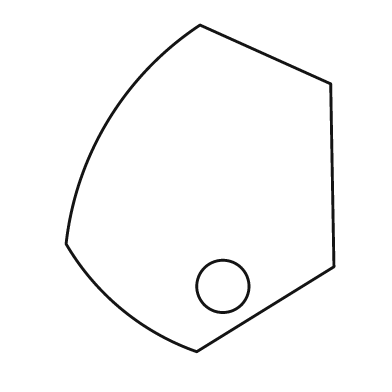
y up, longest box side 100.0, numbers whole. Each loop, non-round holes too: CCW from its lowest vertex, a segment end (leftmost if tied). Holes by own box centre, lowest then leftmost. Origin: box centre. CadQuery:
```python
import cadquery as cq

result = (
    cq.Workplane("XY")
    .moveTo(-1.0, -50.0)
    .lineTo(41.0, -24.0)
    .lineTo(40.0, 32.0)
    .lineTo(0.0, 50.0)
    .threePointArc((-28.0, 21.0), (-41.0, -17.0))
    .threePointArc((-24.0, -37.0), (-1.0, -50.0))
    .close()
    .moveTo(7.0, -30.0)
    .circle(8.0)
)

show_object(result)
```